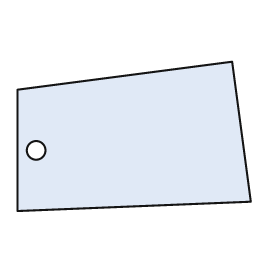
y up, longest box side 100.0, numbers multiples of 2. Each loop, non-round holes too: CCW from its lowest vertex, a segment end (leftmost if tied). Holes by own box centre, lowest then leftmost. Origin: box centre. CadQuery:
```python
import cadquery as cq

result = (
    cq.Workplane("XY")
    .moveTo(-50.0, -32.0)
    .lineTo(50.0, -28.0)
    .lineTo(42.0, 32.0)
    .lineTo(-50.0, 20.0)
    .close()
    .moveTo(-42.0, -6.0)
    .circle(4.0)
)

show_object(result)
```